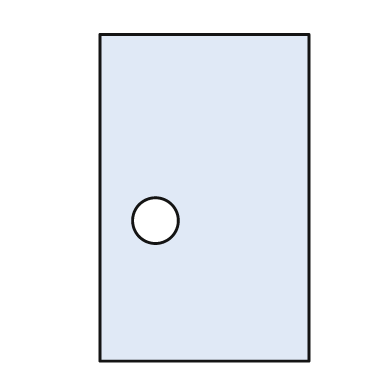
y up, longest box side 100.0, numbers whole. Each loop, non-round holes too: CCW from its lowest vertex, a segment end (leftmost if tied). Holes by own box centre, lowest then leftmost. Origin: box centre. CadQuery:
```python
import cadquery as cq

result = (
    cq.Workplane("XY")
    .moveTo(-32.0, -50.0)
    .lineTo(32.0, -50.0)
    .lineTo(32.0, 50.0)
    .lineTo(-32.0, 50.0)
    .close()
    .moveTo(-15.0, -7.0)
    .circle(7.0)
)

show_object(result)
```